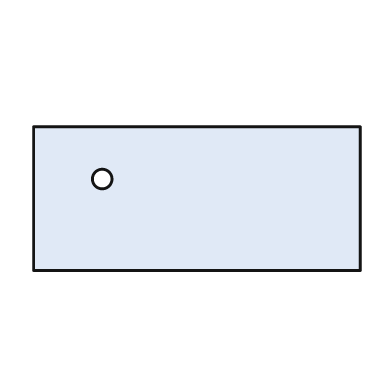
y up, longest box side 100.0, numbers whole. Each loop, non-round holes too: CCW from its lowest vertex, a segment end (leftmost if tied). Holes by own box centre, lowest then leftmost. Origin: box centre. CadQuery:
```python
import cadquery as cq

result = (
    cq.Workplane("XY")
    .moveTo(-50.0, -22.0)
    .lineTo(50.0, -22.0)
    .lineTo(50.0, 22.0)
    .lineTo(-50.0, 22.0)
    .close()
    .moveTo(-29.0, 6.0)
    .circle(3.0)
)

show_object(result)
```